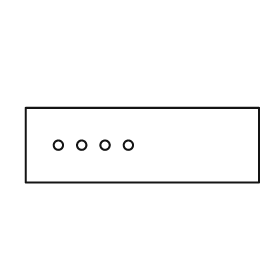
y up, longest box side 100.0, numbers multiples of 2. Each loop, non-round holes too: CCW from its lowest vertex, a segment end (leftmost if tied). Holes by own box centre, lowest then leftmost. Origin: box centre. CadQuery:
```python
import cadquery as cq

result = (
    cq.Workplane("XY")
    .moveTo(-50.0, -16.0)
    .lineTo(50.0, -16.0)
    .lineTo(50.0, 16.0)
    .lineTo(-50.0, 16.0)
    .close()
    .moveTo(-36.0, 0.0)
    .circle(2.0)
    .moveTo(-26.0, 0.0)
    .circle(2.0)
    .moveTo(-16.0, 0.0)
    .circle(2.0)
    .moveTo(-6.0, 0.0)
    .circle(2.0)
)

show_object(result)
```